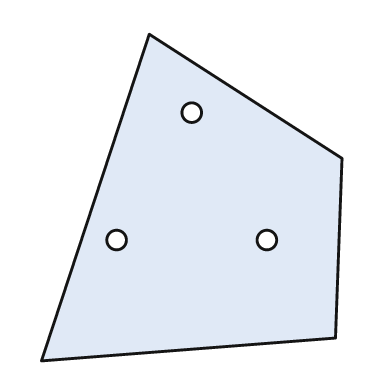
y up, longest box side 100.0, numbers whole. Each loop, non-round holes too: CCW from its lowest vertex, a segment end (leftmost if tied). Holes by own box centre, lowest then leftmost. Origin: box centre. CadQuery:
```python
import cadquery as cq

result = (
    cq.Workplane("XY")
    .moveTo(-46.0, -50.0)
    .lineTo(44.0, -43.0)
    .lineTo(46.0, 12.0)
    .lineTo(-13.0, 50.0)
    .close()
    .moveTo(-23.0, -13.0)
    .circle(3.0)
    .moveTo(23.0, -13.0)
    .circle(3.0)
    .moveTo(0.0, 26.0)
    .circle(3.0)
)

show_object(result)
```